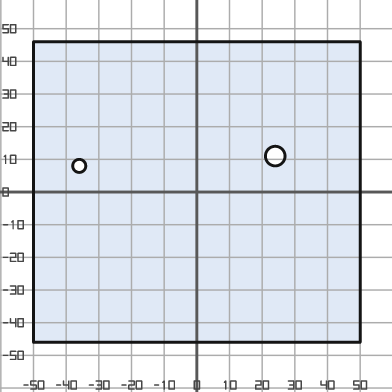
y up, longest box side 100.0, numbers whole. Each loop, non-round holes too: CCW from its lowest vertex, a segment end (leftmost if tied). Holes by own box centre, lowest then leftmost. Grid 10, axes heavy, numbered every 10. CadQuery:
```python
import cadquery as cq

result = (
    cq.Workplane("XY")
    .moveTo(-50.0, -46.0)
    .lineTo(50.0, -46.0)
    .lineTo(50.0, 46.0)
    .lineTo(-50.0, 46.0)
    .close()
    .moveTo(-36.0, 8.0)
    .circle(2.0)
    .moveTo(24.0, 11.0)
    .circle(3.0)
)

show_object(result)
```